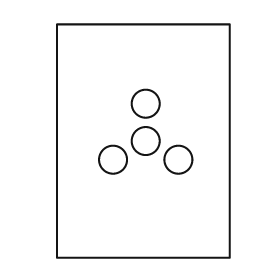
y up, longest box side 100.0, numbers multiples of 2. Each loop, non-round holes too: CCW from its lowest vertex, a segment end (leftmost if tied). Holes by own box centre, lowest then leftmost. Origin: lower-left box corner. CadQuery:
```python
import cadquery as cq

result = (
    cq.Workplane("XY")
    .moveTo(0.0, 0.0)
    .lineTo(74.0, 0.0)
    .lineTo(74.0, 100.0)
    .lineTo(0.0, 100.0)
    .close()
    .moveTo(24.0, 42.0)
    .circle(6.0)
    .moveTo(52.0, 42.0)
    .circle(6.0)
    .moveTo(38.0, 50.0)
    .circle(6.0)
    .moveTo(38.0, 66.0)
    .circle(6.0)
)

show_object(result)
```